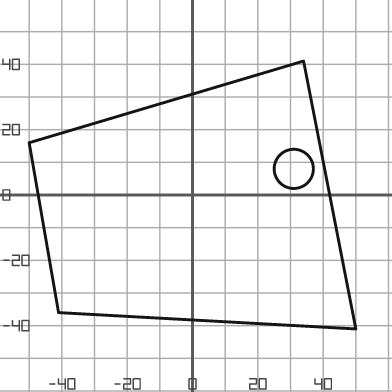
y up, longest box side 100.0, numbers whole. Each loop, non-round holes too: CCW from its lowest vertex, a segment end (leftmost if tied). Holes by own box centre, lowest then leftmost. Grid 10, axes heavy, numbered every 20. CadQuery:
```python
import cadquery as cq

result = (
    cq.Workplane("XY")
    .moveTo(50.0, -41.0)
    .lineTo(34.0, 41.0)
    .lineTo(-50.0, 16.0)
    .lineTo(-41.0, -36.0)
    .close()
    .moveTo(31.0, 8.0)
    .circle(6.0)
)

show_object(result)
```